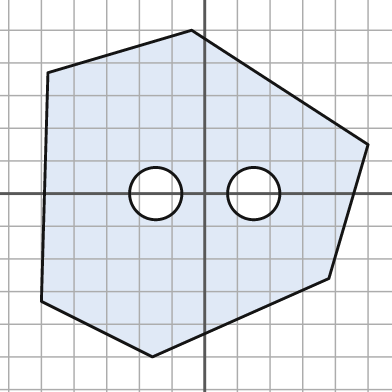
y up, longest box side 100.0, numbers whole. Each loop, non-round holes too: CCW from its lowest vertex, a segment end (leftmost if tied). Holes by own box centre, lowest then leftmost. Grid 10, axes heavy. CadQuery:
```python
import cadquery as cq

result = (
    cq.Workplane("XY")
    .moveTo(-16.0, -50.0)
    .lineTo(38.0, -26.0)
    .lineTo(50.0, 15.0)
    .lineTo(-4.0, 50.0)
    .lineTo(-48.0, 37.0)
    .lineTo(-50.0, -33.0)
    .close()
    .moveTo(-15.0, 0.0)
    .circle(8.0)
    .moveTo(15.0, 0.0)
    .circle(8.0)
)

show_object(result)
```